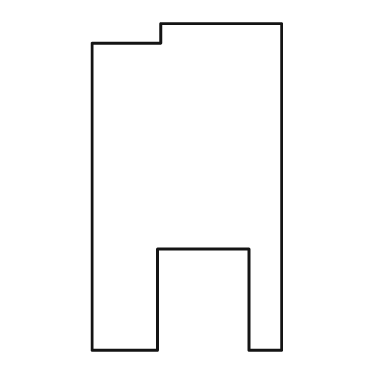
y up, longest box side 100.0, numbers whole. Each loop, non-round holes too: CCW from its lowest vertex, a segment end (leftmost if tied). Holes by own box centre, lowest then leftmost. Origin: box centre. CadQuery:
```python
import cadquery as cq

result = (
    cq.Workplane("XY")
    .moveTo(-29.0, -50.0)
    .lineTo(-9.0, -50.0)
    .lineTo(-9.0, -19.0)
    .lineTo(19.0, -19.0)
    .lineTo(19.0, -50.0)
    .lineTo(29.0, -50.0)
    .lineTo(29.0, 50.0)
    .lineTo(-8.0, 50.0)
    .lineTo(-8.0, 44.0)
    .lineTo(-29.0, 44.0)
    .close()
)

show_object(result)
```